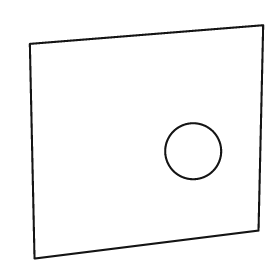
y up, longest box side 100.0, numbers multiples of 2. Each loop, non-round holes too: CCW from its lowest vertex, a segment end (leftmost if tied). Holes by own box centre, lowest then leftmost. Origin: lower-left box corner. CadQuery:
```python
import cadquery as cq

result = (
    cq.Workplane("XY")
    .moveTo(2.0, 0.0)
    .lineTo(98.0, 12.0)
    .lineTo(100.0, 100.0)
    .lineTo(0.0, 92.0)
    .close()
    .moveTo(70.0, 46.0)
    .circle(12.0)
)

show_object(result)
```